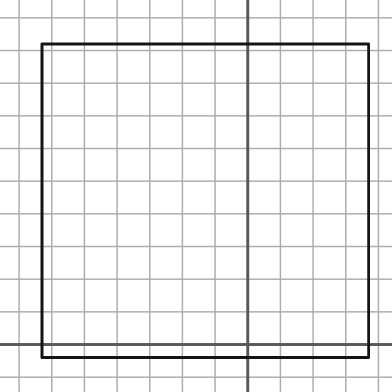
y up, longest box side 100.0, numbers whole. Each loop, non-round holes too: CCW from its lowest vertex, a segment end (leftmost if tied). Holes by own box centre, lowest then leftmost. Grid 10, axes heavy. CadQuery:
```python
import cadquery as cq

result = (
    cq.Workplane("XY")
    .moveTo(-63.0, -4.0)
    .lineTo(37.0, -4.0)
    .lineTo(37.0, 92.0)
    .lineTo(-63.0, 92.0)
    .close()
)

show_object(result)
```